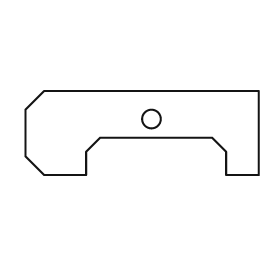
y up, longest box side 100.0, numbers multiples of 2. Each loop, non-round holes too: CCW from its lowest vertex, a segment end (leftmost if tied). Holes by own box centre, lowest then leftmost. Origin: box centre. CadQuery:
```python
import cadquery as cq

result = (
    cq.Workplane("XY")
    .moveTo(-42.0, -18.0)
    .lineTo(-24.0, -18.0)
    .lineTo(-24.0, -8.0)
    .lineTo(-18.0, -2.0)
    .lineTo(30.0, -2.0)
    .lineTo(36.0, -8.0)
    .lineTo(36.0, -18.0)
    .lineTo(50.0, -18.0)
    .lineTo(50.0, 18.0)
    .lineTo(-42.0, 18.0)
    .lineTo(-50.0, 10.0)
    .lineTo(-50.0, -10.0)
    .close()
    .moveTo(4.0, 6.0)
    .circle(4.0)
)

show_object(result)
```